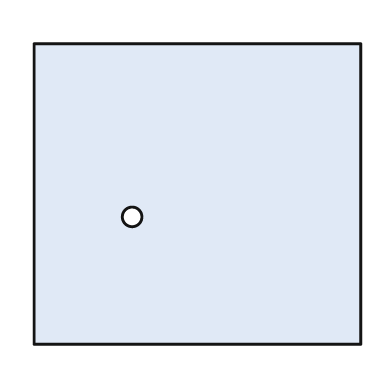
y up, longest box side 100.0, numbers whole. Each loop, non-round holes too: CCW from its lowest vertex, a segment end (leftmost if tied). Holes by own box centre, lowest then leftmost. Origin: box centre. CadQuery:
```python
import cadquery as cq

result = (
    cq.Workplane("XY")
    .moveTo(-50.0, -46.0)
    .lineTo(50.0, -46.0)
    .lineTo(50.0, 46.0)
    .lineTo(-50.0, 46.0)
    .close()
    .moveTo(-20.0, -7.0)
    .circle(3.0)
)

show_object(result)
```